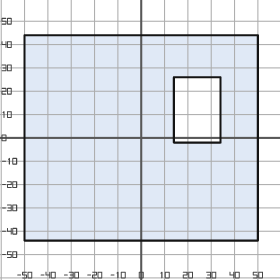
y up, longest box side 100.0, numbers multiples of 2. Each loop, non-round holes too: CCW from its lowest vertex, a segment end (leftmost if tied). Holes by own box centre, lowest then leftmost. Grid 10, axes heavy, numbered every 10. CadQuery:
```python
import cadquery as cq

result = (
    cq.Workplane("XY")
    .moveTo(-50.0, -44.0)
    .lineTo(50.0, -44.0)
    .lineTo(50.0, 44.0)
    .lineTo(-50.0, 44.0)
    .close()
    .moveTo(14.0, -2.0)
    .lineTo(34.0, -2.0)
    .lineTo(34.0, 26.0)
    .lineTo(14.0, 26.0)
    .close()
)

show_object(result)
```